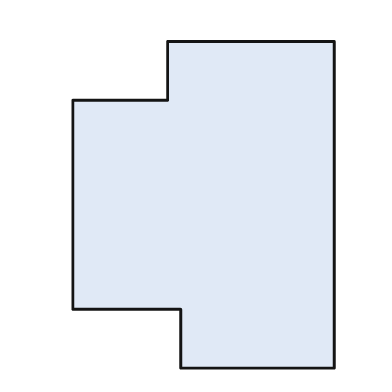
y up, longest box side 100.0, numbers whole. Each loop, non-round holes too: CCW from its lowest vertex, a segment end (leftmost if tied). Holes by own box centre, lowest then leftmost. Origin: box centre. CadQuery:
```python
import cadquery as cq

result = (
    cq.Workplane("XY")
    .moveTo(-7.0, -50.0)
    .lineTo(40.0, -50.0)
    .lineTo(40.0, 50.0)
    .lineTo(-11.0, 50.0)
    .lineTo(-11.0, 32.0)
    .lineTo(-40.0, 32.0)
    .lineTo(-40.0, -32.0)
    .lineTo(-7.0, -32.0)
    .close()
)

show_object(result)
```